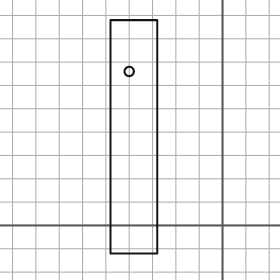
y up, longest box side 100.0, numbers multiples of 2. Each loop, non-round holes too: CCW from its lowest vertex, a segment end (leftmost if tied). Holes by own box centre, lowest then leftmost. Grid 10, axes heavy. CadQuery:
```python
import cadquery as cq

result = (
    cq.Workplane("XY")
    .moveTo(-48.0, -12.0)
    .lineTo(-28.0, -12.0)
    .lineTo(-28.0, 88.0)
    .lineTo(-48.0, 88.0)
    .close()
    .moveTo(-40.0, 66.0)
    .circle(2.0)
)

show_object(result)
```